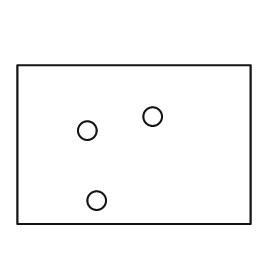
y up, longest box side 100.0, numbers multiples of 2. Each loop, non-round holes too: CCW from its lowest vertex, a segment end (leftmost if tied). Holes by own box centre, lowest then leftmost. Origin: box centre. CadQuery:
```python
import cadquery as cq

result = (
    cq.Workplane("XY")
    .moveTo(-50.0, -34.0)
    .lineTo(50.0, -34.0)
    .lineTo(50.0, 34.0)
    .lineTo(-50.0, 34.0)
    .close()
    .moveTo(-16.0, -24.0)
    .circle(4.0)
    .moveTo(-20.0, 6.0)
    .circle(4.0)
    .moveTo(8.0, 12.0)
    .circle(4.0)
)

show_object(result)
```